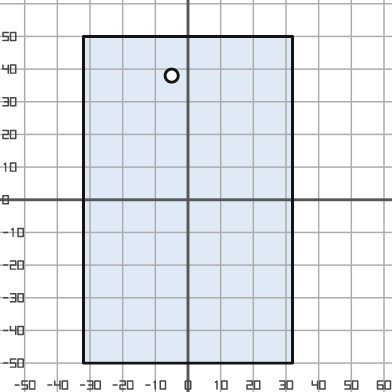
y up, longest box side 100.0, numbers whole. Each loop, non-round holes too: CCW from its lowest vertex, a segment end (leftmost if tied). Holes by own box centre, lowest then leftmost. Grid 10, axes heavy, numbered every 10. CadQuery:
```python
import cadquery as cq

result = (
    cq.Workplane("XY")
    .moveTo(-32.0, -50.0)
    .lineTo(32.0, -50.0)
    .lineTo(32.0, 50.0)
    .lineTo(-32.0, 50.0)
    .close()
    .moveTo(-5.0, 38.0)
    .circle(2.0)
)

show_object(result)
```